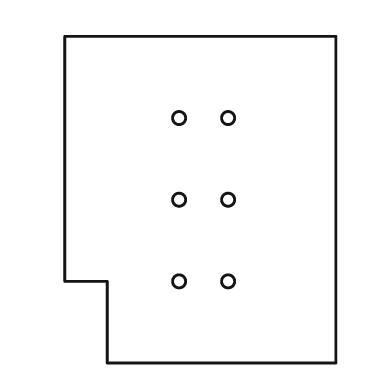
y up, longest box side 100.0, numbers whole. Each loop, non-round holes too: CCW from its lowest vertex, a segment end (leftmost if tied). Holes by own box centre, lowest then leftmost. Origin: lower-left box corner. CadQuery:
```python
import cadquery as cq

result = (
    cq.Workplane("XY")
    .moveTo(13.0, 0.0)
    .lineTo(83.0, 0.0)
    .lineTo(83.0, 100.0)
    .lineTo(0.0, 100.0)
    .lineTo(0.0, 25.0)
    .lineTo(13.0, 25.0)
    .close()
    .moveTo(35.0, 25.0)
    .circle(2.0)
    .moveTo(50.0, 25.0)
    .circle(2.0)
    .moveTo(35.0, 50.0)
    .circle(2.0)
    .moveTo(50.0, 50.0)
    .circle(2.0)
    .moveTo(35.0, 75.0)
    .circle(2.0)
    .moveTo(50.0, 75.0)
    .circle(2.0)
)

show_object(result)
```